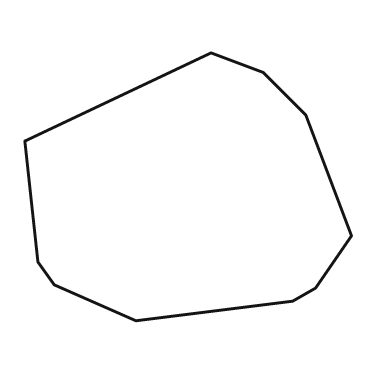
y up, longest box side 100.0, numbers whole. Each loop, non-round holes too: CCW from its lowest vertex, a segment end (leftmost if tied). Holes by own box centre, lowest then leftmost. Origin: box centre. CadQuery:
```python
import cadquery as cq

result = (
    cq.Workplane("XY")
    .moveTo(-16.0, -41.0)
    .lineTo(32.0, -35.0)
    .lineTo(39.0, -31.0)
    .lineTo(50.0, -15.0)
    .lineTo(36.0, 22.0)
    .lineTo(23.0, 35.0)
    .lineTo(7.0, 41.0)
    .lineTo(-50.0, 14.0)
    .lineTo(-46.0, -23.0)
    .lineTo(-41.0, -30.0)
    .close()
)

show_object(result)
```